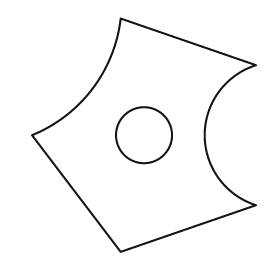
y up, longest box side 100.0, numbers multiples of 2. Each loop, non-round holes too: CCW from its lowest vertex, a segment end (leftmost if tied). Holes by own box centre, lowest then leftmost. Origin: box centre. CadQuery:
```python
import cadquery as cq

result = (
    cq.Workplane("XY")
    .moveTo(-10.0, -50.0)
    .lineTo(48.0, -30.0)
    .threePointArc((26.0, 0.0), (48.0, 30.0))
    .lineTo(-10.0, 50.0)
    .threePointArc((-22.0, 20.0), (-48.0, 0.0))
    .close()
    .moveTo(0.0, 0.0)
    .circle(12.0)
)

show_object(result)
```